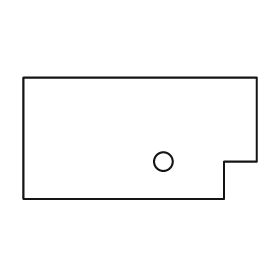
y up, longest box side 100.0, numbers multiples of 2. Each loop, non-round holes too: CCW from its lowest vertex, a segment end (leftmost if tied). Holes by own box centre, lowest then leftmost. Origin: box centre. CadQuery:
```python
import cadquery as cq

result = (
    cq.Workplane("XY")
    .moveTo(-50.0, -26.0)
    .lineTo(36.0, -26.0)
    .lineTo(36.0, -10.0)
    .lineTo(50.0, -10.0)
    .lineTo(50.0, 26.0)
    .lineTo(-50.0, 26.0)
    .close()
    .moveTo(10.0, -10.0)
    .circle(4.0)
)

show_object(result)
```